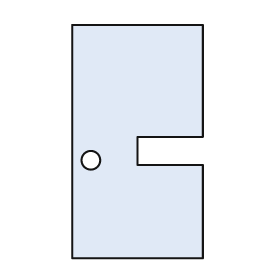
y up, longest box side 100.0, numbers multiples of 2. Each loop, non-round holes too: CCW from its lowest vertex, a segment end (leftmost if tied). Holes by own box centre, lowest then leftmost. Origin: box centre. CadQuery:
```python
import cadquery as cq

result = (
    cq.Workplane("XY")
    .moveTo(-28.0, -50.0)
    .lineTo(28.0, -50.0)
    .lineTo(28.0, -10.0)
    .lineTo(0.0, -10.0)
    .lineTo(0.0, 2.0)
    .lineTo(28.0, 2.0)
    .lineTo(28.0, 50.0)
    .lineTo(-28.0, 50.0)
    .close()
    .moveTo(-20.0, -8.0)
    .circle(4.0)
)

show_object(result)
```